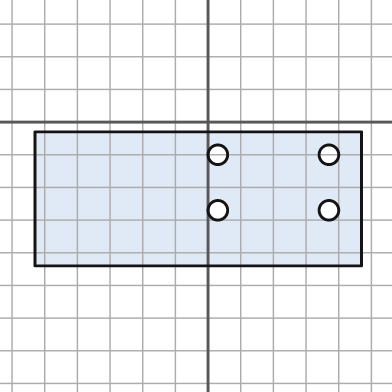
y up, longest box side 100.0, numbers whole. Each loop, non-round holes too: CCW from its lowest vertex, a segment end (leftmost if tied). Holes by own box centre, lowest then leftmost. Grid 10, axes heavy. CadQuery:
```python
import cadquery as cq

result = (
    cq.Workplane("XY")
    .moveTo(-53.0, -44.0)
    .lineTo(47.0, -44.0)
    .lineTo(47.0, -3.0)
    .lineTo(-53.0, -3.0)
    .close()
    .moveTo(3.0, -27.0)
    .circle(3.0)
    .moveTo(37.0, -27.0)
    .circle(3.0)
    .moveTo(3.0, -10.0)
    .circle(3.0)
    .moveTo(37.0, -10.0)
    .circle(3.0)
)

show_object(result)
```